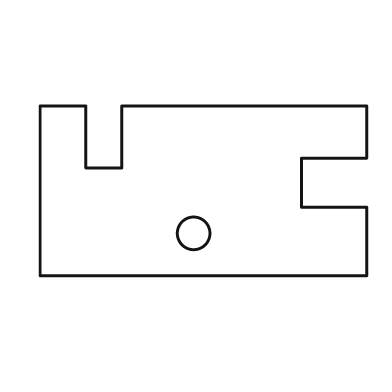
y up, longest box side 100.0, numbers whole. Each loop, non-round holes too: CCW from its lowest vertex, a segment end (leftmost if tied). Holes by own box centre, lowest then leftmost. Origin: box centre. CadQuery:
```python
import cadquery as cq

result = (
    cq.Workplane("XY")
    .moveTo(-50.0, -26.0)
    .lineTo(50.0, -26.0)
    .lineTo(50.0, -5.0)
    .lineTo(30.0, -5.0)
    .lineTo(30.0, 10.0)
    .lineTo(50.0, 10.0)
    .lineTo(50.0, 26.0)
    .lineTo(-25.0, 26.0)
    .lineTo(-25.0, 7.0)
    .lineTo(-36.0, 7.0)
    .lineTo(-36.0, 26.0)
    .lineTo(-50.0, 26.0)
    .close()
    .moveTo(-3.0, -13.0)
    .circle(5.0)
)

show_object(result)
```